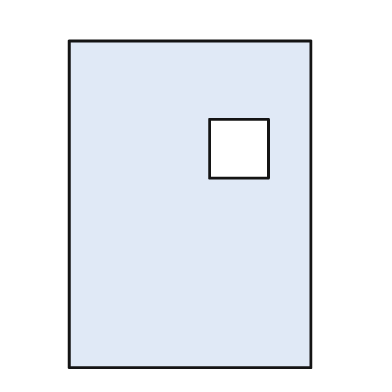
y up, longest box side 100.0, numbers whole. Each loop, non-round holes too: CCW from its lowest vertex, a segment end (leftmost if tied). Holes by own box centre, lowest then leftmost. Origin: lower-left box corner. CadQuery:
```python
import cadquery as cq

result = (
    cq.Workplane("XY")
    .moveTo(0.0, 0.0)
    .lineTo(74.0, 0.0)
    .lineTo(74.0, 100.0)
    .lineTo(0.0, 100.0)
    .close()
    .moveTo(43.0, 58.0)
    .lineTo(61.0, 58.0)
    .lineTo(61.0, 76.0)
    .lineTo(43.0, 76.0)
    .close()
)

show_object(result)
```